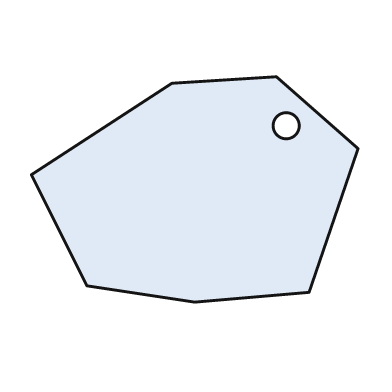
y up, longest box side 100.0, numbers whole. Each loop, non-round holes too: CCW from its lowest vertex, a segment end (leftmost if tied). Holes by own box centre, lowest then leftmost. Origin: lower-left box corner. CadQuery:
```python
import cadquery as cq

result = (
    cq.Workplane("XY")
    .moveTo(50.0, 0.0)
    .lineTo(85.0, 3.0)
    .lineTo(100.0, 47.0)
    .lineTo(75.0, 69.0)
    .lineTo(43.0, 67.0)
    .lineTo(0.0, 39.0)
    .lineTo(17.0, 5.0)
    .close()
    .moveTo(78.0, 54.0)
    .circle(4.0)
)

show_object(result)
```